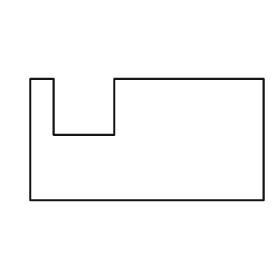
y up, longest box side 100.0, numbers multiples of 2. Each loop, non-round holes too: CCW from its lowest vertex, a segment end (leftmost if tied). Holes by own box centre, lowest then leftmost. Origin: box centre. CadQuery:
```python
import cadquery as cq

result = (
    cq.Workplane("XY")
    .moveTo(-50.0, -26.0)
    .lineTo(50.0, -26.0)
    .lineTo(50.0, 26.0)
    .lineTo(-14.0, 26.0)
    .lineTo(-14.0, 2.0)
    .lineTo(-40.0, 2.0)
    .lineTo(-40.0, 26.0)
    .lineTo(-50.0, 26.0)
    .close()
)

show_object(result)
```